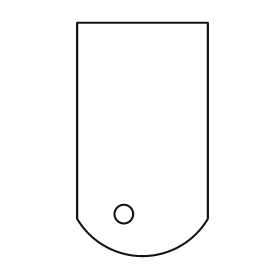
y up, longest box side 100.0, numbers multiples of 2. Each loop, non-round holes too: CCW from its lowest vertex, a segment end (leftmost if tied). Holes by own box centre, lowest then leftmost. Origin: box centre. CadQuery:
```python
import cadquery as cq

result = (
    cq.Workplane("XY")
    .moveTo(-28.0, -34.0)
    .threePointArc((0.0, -50.0), (28.0, -34.0))
    .lineTo(28.0, 50.0)
    .lineTo(-28.0, 50.0)
    .close()
    .moveTo(-8.0, -32.0)
    .circle(4.0)
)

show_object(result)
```